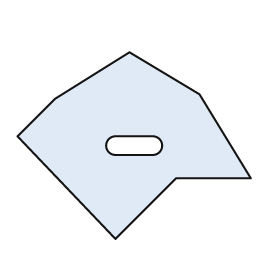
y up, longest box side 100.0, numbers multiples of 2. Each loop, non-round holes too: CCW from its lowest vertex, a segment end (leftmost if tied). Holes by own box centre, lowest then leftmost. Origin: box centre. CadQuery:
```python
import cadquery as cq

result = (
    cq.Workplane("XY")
    .moveTo(-8.0, -40.0)
    .lineTo(18.0, -14.0)
    .lineTo(50.0, -14.0)
    .lineTo(28.0, 22.0)
    .lineTo(-2.0, 40.0)
    .lineTo(-34.0, 20.0)
    .lineTo(-50.0, 4.0)
    .close()
    .moveTo(-8.0, -4.0)
    .lineTo(8.0, -4.0)
    .threePointArc((12.0, 0.0), (8.0, 4.0))
    .lineTo(-8.0, 4.0)
    .threePointArc((-12.0, 0.0), (-8.0, -4.0))
    .close()
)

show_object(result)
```